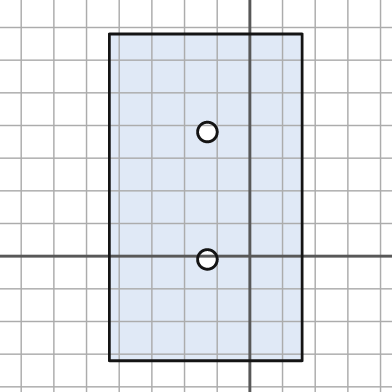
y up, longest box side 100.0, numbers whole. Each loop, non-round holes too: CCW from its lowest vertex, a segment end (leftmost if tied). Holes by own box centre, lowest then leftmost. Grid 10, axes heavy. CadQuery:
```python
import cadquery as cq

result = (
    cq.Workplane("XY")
    .moveTo(-43.0, -32.0)
    .lineTo(16.0, -32.0)
    .lineTo(16.0, 68.0)
    .lineTo(-43.0, 68.0)
    .close()
    .moveTo(-13.0, -1.0)
    .circle(3.0)
    .moveTo(-13.0, 38.0)
    .circle(3.0)
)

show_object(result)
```